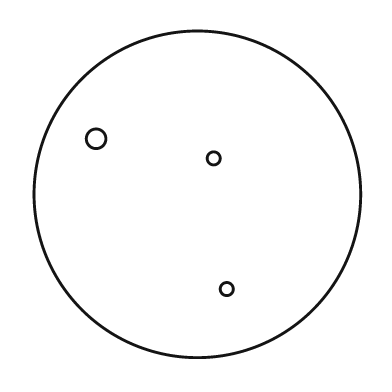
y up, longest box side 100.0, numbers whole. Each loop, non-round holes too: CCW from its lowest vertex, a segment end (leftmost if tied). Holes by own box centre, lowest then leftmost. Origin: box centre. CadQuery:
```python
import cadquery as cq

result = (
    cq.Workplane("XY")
    .moveTo(0.0, 0.0)
    .circle(50.0)
    .moveTo(9.0, -29.0)
    .circle(2.0)
    .moveTo(5.0, 11.0)
    .circle(2.0)
    .moveTo(-31.0, 17.0)
    .circle(3.0)
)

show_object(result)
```